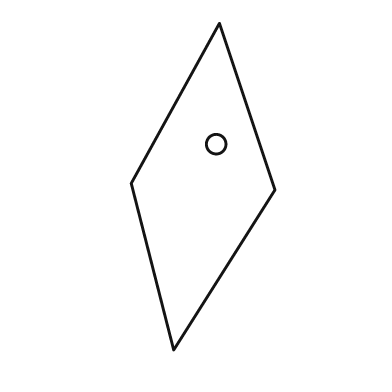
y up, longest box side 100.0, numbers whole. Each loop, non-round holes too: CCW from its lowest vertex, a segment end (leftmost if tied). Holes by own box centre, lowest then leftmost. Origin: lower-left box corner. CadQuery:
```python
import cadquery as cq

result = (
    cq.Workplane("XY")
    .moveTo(13.0, 0.0)
    .lineTo(44.0, 49.0)
    .lineTo(27.0, 100.0)
    .lineTo(0.0, 51.0)
    .close()
    .moveTo(26.0, 63.0)
    .circle(3.0)
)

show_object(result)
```